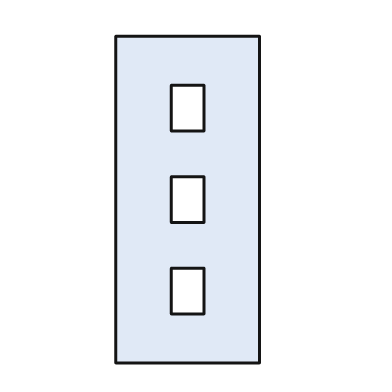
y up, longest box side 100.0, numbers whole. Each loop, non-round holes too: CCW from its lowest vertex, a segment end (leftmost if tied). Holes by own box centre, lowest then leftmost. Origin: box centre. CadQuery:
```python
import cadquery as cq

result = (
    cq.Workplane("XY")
    .moveTo(-22.0, -50.0)
    .lineTo(22.0, -50.0)
    .lineTo(22.0, 50.0)
    .lineTo(-22.0, 50.0)
    .close()
    .moveTo(-5.0, -35.0)
    .lineTo(5.0, -35.0)
    .lineTo(5.0, -21.0)
    .lineTo(-5.0, -21.0)
    .close()
    .moveTo(-5.0, -7.0)
    .lineTo(5.0, -7.0)
    .lineTo(5.0, 7.0)
    .lineTo(-5.0, 7.0)
    .close()
    .moveTo(-5.0, 21.0)
    .lineTo(5.0, 21.0)
    .lineTo(5.0, 35.0)
    .lineTo(-5.0, 35.0)
    .close()
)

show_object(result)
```